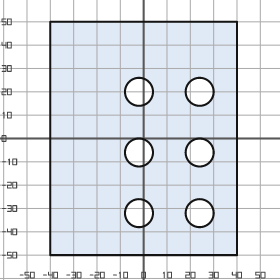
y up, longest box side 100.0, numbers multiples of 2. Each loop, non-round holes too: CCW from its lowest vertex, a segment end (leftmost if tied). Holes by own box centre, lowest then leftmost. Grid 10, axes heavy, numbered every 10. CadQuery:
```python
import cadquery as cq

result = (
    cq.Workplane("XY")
    .moveTo(-40.0, -50.0)
    .lineTo(40.0, -50.0)
    .lineTo(40.0, 50.0)
    .lineTo(-40.0, 50.0)
    .close()
    .moveTo(-2.0, -32.0)
    .circle(6.0)
    .moveTo(24.0, -32.0)
    .circle(6.0)
    .moveTo(-2.0, -6.0)
    .circle(6.0)
    .moveTo(24.0, -6.0)
    .circle(6.0)
    .moveTo(-2.0, 20.0)
    .circle(6.0)
    .moveTo(24.0, 20.0)
    .circle(6.0)
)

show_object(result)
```